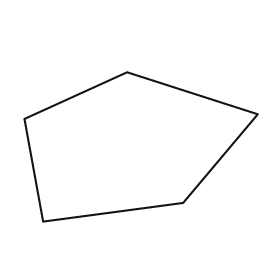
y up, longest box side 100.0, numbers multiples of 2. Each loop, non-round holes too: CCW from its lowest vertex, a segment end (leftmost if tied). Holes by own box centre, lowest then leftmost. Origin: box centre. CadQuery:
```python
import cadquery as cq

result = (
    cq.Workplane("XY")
    .moveTo(-42.0, -32.0)
    .lineTo(18.0, -24.0)
    .lineTo(50.0, 14.0)
    .lineTo(-6.0, 32.0)
    .lineTo(-50.0, 12.0)
    .close()
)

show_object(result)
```